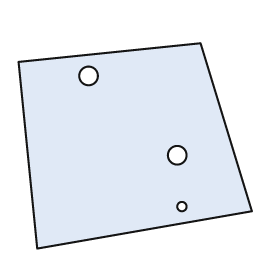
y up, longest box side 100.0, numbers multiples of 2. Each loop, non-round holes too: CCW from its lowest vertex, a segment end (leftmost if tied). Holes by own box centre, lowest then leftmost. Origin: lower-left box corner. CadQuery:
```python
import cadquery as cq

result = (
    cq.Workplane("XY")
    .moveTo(8.0, 0.0)
    .lineTo(100.0, 16.0)
    .lineTo(78.0, 88.0)
    .lineTo(0.0, 80.0)
    .close()
    .moveTo(70.0, 18.0)
    .circle(2.0)
    .moveTo(68.0, 40.0)
    .circle(4.0)
    .moveTo(30.0, 74.0)
    .circle(4.0)
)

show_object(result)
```